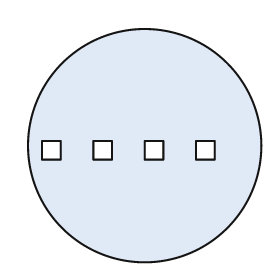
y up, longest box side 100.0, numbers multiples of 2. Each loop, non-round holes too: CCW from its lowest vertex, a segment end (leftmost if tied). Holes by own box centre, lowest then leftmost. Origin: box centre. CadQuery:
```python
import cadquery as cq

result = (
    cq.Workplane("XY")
    .moveTo(0.0, 0.0)
    .circle(50.0)
    .moveTo(-44.0, -6.0)
    .lineTo(-36.0, -6.0)
    .lineTo(-36.0, 2.0)
    .lineTo(-44.0, 2.0)
    .close()
    .moveTo(-22.0, -6.0)
    .lineTo(-14.0, -6.0)
    .lineTo(-14.0, 2.0)
    .lineTo(-22.0, 2.0)
    .close()
    .moveTo(0.0, -6.0)
    .lineTo(8.0, -6.0)
    .lineTo(8.0, 2.0)
    .lineTo(0.0, 2.0)
    .close()
    .moveTo(22.0, -6.0)
    .lineTo(30.0, -6.0)
    .lineTo(30.0, 2.0)
    .lineTo(22.0, 2.0)
    .close()
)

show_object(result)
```